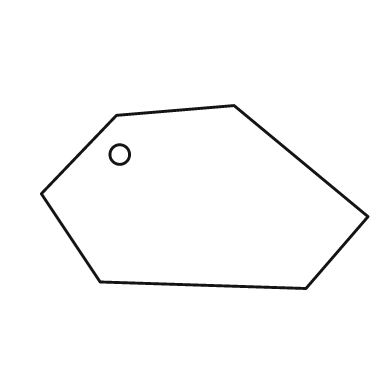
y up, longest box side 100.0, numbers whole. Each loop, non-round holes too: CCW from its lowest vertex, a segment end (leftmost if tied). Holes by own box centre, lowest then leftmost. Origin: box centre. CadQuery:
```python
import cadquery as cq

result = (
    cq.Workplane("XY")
    .moveTo(31.0, -28.0)
    .lineTo(50.0, -6.0)
    .lineTo(9.0, 28.0)
    .lineTo(-27.0, 25.0)
    .lineTo(-50.0, 1.0)
    .lineTo(-32.0, -26.0)
    .close()
    .moveTo(-26.0, 13.0)
    .circle(3.0)
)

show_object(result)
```